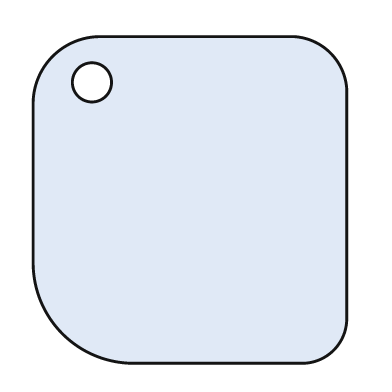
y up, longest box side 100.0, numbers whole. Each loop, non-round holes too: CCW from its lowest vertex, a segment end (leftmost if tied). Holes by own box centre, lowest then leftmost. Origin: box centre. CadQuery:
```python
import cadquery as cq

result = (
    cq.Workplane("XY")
    .moveTo(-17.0, -50.0)
    .lineTo(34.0, -50.0)
    .threePointArc((44.0, -46.0), (48.0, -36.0))
    .lineTo(48.0, 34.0)
    .threePointArc((43.0, 45.0), (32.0, 50.0))
    .lineTo(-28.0, 50.0)
    .threePointArc((-42.0, 44.0), (-48.0, 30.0))
    .lineTo(-48.0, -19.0)
    .threePointArc((-39.0, -41.0), (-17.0, -50.0))
    .close()
    .moveTo(-30.0, 36.0)
    .circle(6.0)
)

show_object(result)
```